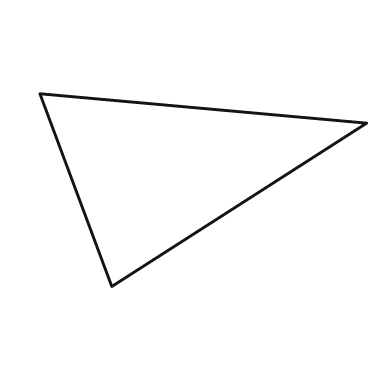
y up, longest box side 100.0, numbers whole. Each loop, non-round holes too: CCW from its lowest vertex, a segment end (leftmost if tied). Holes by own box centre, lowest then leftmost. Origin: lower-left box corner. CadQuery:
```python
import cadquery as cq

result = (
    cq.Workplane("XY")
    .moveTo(22.0, 0.0)
    .lineTo(100.0, 50.0)
    .lineTo(0.0, 59.0)
    .close()
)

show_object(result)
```